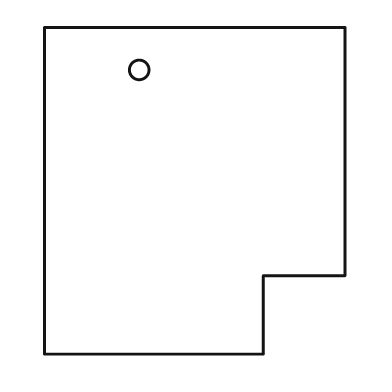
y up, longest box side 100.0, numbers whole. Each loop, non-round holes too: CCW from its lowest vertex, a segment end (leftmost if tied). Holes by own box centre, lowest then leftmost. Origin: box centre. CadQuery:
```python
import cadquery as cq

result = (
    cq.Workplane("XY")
    .moveTo(-46.0, -50.0)
    .lineTo(21.0, -50.0)
    .lineTo(21.0, -26.0)
    .lineTo(46.0, -26.0)
    .lineTo(46.0, 50.0)
    .lineTo(-46.0, 50.0)
    .close()
    .moveTo(-17.0, 37.0)
    .circle(3.0)
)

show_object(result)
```